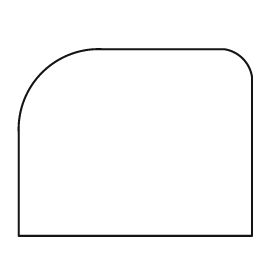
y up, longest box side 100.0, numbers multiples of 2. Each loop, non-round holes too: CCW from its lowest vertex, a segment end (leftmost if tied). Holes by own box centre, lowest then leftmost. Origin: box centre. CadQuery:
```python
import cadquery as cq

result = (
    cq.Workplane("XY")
    .moveTo(-50.0, -40.0)
    .lineTo(50.0, -40.0)
    .lineTo(50.0, 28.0)
    .threePointArc((46.0, 36.0), (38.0, 40.0))
    .lineTo(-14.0, 40.0)
    .threePointArc((-40.0, 30.0), (-50.0, 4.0))
    .close()
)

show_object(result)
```